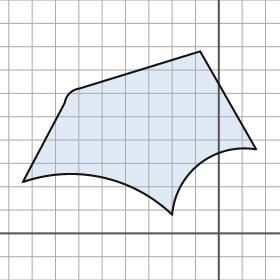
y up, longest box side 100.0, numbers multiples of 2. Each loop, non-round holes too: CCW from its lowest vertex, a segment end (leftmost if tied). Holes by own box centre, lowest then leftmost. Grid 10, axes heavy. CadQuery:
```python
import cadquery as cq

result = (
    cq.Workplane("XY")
    .moveTo(-20.0, 8.0)
    .threePointArc((-8.0, 30.0), (16.0, 36.0))
    .lineTo(-8.0, 78.0)
    .lineTo(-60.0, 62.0)
    .threePointArc((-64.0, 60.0), (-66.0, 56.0))
    .lineTo(-84.0, 22.0)
    .threePointArc((-50.0, 24.0), (-20.0, 8.0))
    .close()
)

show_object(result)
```